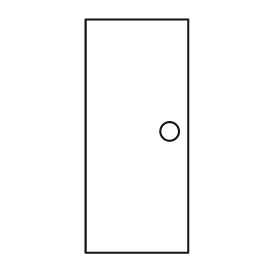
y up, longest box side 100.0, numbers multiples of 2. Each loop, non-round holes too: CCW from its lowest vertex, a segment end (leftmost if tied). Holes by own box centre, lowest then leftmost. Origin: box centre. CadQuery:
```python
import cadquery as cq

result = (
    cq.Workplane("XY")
    .moveTo(-22.0, -50.0)
    .lineTo(22.0, -50.0)
    .lineTo(22.0, 50.0)
    .lineTo(-22.0, 50.0)
    .close()
    .moveTo(14.0, 2.0)
    .circle(4.0)
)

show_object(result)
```